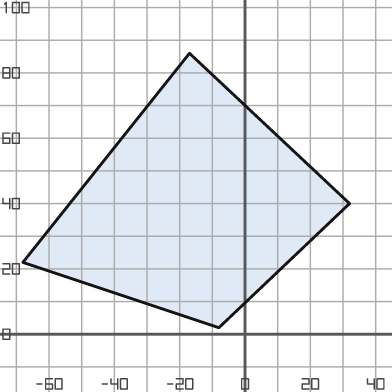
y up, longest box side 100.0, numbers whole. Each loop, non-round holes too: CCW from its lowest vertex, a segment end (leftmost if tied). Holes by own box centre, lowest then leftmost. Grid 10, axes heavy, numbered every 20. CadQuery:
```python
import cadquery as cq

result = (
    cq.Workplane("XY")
    .moveTo(-8.0, 2.0)
    .lineTo(32.0, 40.0)
    .lineTo(-17.0, 86.0)
    .lineTo(-68.0, 22.0)
    .close()
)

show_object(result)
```